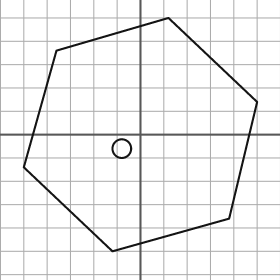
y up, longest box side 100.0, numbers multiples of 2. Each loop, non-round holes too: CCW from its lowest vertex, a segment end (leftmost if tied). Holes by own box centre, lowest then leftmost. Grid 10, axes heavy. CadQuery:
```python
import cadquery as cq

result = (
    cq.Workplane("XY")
    .moveTo(-12.0, -50.0)
    .lineTo(38.0, -36.0)
    .lineTo(50.0, 14.0)
    .lineTo(12.0, 50.0)
    .lineTo(-36.0, 36.0)
    .lineTo(-50.0, -14.0)
    .close()
    .moveTo(-8.0, -6.0)
    .circle(4.0)
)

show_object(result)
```